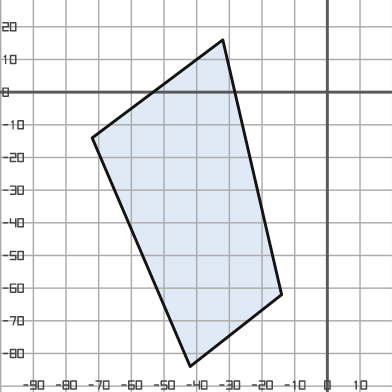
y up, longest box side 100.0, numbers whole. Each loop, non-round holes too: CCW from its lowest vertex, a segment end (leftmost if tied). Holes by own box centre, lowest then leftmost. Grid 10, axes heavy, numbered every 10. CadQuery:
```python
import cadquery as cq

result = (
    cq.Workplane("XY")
    .moveTo(-42.0, -84.0)
    .lineTo(-14.0, -62.0)
    .lineTo(-32.0, 16.0)
    .lineTo(-72.0, -14.0)
    .close()
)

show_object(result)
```